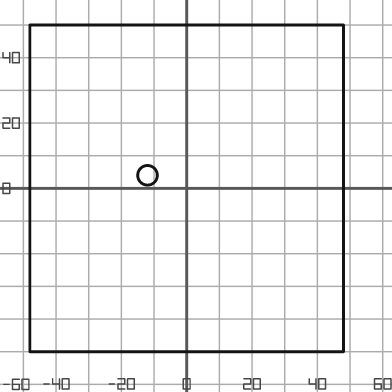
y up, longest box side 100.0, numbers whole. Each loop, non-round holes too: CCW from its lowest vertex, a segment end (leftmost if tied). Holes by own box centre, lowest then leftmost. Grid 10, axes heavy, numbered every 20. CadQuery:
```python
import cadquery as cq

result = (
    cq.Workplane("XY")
    .moveTo(-48.0, -50.0)
    .lineTo(48.0, -50.0)
    .lineTo(48.0, 50.0)
    .lineTo(-48.0, 50.0)
    .close()
    .moveTo(-12.0, 4.0)
    .circle(3.0)
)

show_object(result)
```